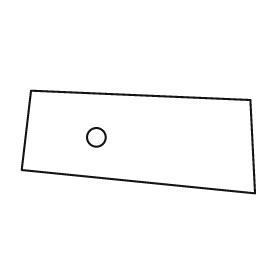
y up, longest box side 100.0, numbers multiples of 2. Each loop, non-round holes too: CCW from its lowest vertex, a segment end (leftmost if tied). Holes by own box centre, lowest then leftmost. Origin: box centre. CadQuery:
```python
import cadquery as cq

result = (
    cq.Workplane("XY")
    .moveTo(50.0, -22.0)
    .lineTo(48.0, 18.0)
    .lineTo(-46.0, 22.0)
    .lineTo(-50.0, -12.0)
    .close()
    .moveTo(-18.0, 2.0)
    .circle(4.0)
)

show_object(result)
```